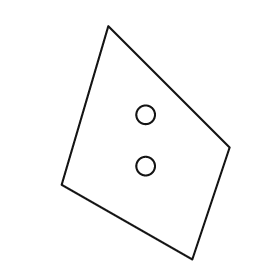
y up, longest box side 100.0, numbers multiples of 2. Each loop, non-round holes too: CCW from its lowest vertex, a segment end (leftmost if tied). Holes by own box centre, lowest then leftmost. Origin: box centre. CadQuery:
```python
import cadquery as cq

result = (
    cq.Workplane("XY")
    .moveTo(20.0, -50.0)
    .lineTo(36.0, -2.0)
    .lineTo(-16.0, 50.0)
    .lineTo(-36.0, -18.0)
    .close()
    .moveTo(0.0, -10.0)
    .circle(4.0)
    .moveTo(0.0, 12.0)
    .circle(4.0)
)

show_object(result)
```